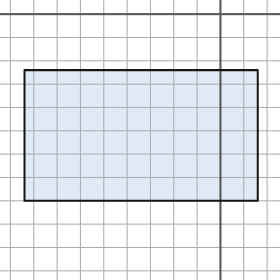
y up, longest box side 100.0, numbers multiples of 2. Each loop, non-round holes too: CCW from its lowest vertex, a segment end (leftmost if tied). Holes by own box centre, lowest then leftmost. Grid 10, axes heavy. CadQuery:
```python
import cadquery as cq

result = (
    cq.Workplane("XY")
    .moveTo(-84.0, -80.0)
    .lineTo(16.0, -80.0)
    .lineTo(16.0, -24.0)
    .lineTo(-84.0, -24.0)
    .close()
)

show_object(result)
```